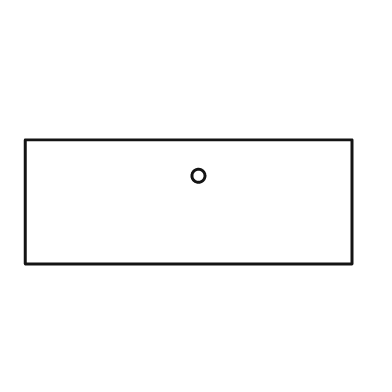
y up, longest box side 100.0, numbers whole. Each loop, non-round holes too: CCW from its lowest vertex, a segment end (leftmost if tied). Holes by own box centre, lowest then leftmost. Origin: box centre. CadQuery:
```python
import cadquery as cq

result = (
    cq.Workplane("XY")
    .moveTo(-50.0, -19.0)
    .lineTo(50.0, -19.0)
    .lineTo(50.0, 19.0)
    .lineTo(-50.0, 19.0)
    .close()
    .moveTo(3.0, 8.0)
    .circle(2.0)
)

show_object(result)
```